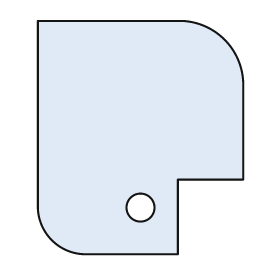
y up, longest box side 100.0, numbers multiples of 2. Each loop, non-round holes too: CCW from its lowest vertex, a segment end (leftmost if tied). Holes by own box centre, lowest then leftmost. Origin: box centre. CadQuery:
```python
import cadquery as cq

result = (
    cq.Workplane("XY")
    .moveTo(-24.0, -50.0)
    .lineTo(16.0, -50.0)
    .lineTo(16.0, -18.0)
    .lineTo(44.0, -18.0)
    .lineTo(44.0, 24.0)
    .threePointArc((36.0, 42.0), (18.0, 50.0))
    .lineTo(-44.0, 50.0)
    .lineTo(-44.0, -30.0)
    .threePointArc((-38.0, -44.0), (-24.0, -50.0))
    .close()
    .moveTo(0.0, -30.0)
    .circle(6.0)
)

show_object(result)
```